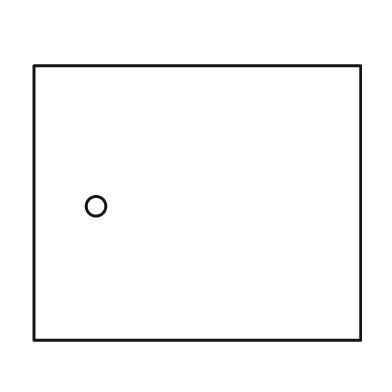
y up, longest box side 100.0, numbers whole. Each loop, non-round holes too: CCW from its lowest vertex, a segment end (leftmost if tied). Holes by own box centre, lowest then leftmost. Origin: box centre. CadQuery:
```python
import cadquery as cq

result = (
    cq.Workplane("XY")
    .moveTo(-50.0, -42.0)
    .lineTo(50.0, -42.0)
    .lineTo(50.0, 42.0)
    .lineTo(-50.0, 42.0)
    .close()
    .moveTo(-31.0, -1.0)
    .circle(3.0)
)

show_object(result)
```